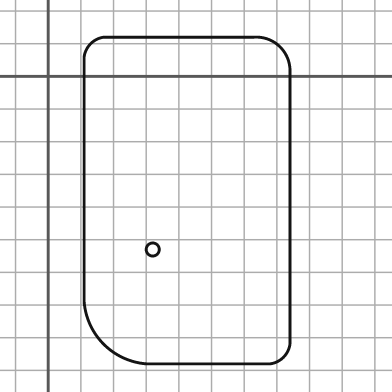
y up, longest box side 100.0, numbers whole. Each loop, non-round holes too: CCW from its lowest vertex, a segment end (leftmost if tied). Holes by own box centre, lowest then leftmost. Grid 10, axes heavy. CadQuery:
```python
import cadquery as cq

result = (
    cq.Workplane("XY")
    .moveTo(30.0, -88.0)
    .lineTo(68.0, -88.0)
    .threePointArc((72.0, -86.0), (74.0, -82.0))
    .lineTo(74.0, 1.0)
    .threePointArc((71.0, 9.0), (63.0, 12.0))
    .lineTo(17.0, 12.0)
    .threePointArc((13.0, 10.0), (11.0, 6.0))
    .lineTo(11.0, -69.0)
    .threePointArc((17.0, -82.0), (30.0, -88.0))
    .close()
    .moveTo(32.0, -53.0)
    .circle(2.0)
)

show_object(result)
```